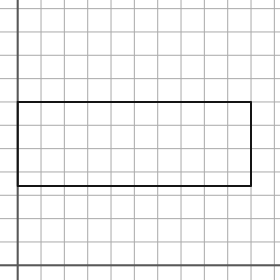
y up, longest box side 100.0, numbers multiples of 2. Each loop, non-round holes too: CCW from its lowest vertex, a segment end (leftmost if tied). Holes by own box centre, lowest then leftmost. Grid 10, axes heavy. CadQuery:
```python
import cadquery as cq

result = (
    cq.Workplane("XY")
    .moveTo(0.0, 34.0)
    .lineTo(100.0, 34.0)
    .lineTo(100.0, 70.0)
    .lineTo(0.0, 70.0)
    .close()
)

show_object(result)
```